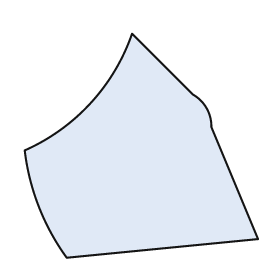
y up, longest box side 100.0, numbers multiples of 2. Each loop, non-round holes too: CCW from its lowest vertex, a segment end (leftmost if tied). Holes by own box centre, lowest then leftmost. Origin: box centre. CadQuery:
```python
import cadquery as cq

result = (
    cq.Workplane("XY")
    .moveTo(-32.0, -48.0)
    .lineTo(50.0, -40.0)
    .lineTo(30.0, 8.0)
    .threePointArc((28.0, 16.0), (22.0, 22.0))
    .lineTo(-4.0, 48.0)
    .threePointArc((-22.0, 18.0), (-50.0, -2.0))
    .threePointArc((-44.0, -26.0), (-32.0, -48.0))
    .close()
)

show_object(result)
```